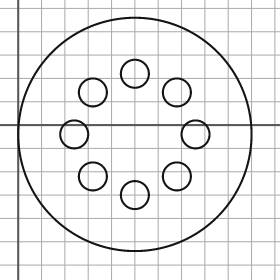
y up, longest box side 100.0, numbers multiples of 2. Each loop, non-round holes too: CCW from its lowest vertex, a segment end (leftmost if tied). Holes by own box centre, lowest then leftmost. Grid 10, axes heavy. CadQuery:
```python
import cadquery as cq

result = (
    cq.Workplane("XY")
    .moveTo(50.0, -4.0)
    .circle(50.0)
    .moveTo(50.0, -30.0)
    .circle(6.0)
    .moveTo(32.0, -22.0)
    .circle(6.0)
    .moveTo(68.0, -22.0)
    .circle(6.0)
    .moveTo(24.0, -4.0)
    .circle(6.0)
    .moveTo(76.0, -4.0)
    .circle(6.0)
    .moveTo(32.0, 14.0)
    .circle(6.0)
    .moveTo(68.0, 14.0)
    .circle(6.0)
    .moveTo(50.0, 22.0)
    .circle(6.0)
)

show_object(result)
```